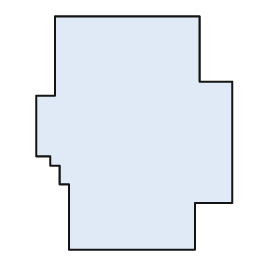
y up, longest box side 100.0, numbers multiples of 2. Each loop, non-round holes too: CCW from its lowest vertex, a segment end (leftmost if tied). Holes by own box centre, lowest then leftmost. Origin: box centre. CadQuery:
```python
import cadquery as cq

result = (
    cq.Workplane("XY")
    .moveTo(-28.0, -50.0)
    .lineTo(26.0, -50.0)
    .lineTo(26.0, -30.0)
    .lineTo(42.0, -30.0)
    .lineTo(42.0, 22.0)
    .lineTo(28.0, 22.0)
    .lineTo(28.0, 50.0)
    .lineTo(-34.0, 50.0)
    .lineTo(-34.0, 16.0)
    .lineTo(-42.0, 16.0)
    .lineTo(-42.0, -10.0)
    .lineTo(-36.0, -10.0)
    .lineTo(-36.0, -14.0)
    .lineTo(-32.0, -14.0)
    .lineTo(-32.0, -22.0)
    .lineTo(-28.0, -22.0)
    .close()
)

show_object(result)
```